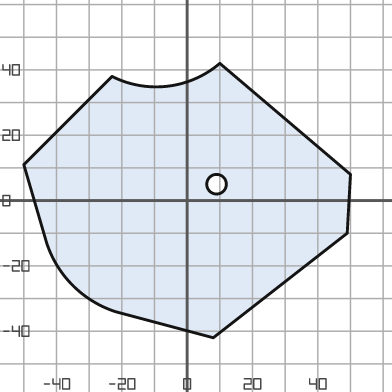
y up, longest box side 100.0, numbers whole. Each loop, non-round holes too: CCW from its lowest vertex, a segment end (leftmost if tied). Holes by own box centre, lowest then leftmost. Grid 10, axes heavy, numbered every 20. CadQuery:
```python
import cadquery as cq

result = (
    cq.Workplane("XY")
    .moveTo(8.0, -42.0)
    .lineTo(49.0, -10.0)
    .lineTo(50.0, 8.0)
    .lineTo(10.0, 42.0)
    .threePointArc((-6.0, 35.0), (-23.0, 38.0))
    .lineTo(-50.0, 11.0)
    .lineTo(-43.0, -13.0)
    .threePointArc((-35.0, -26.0), (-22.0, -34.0))
    .close()
    .moveTo(9.0, 5.0)
    .circle(3.0)
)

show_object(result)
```